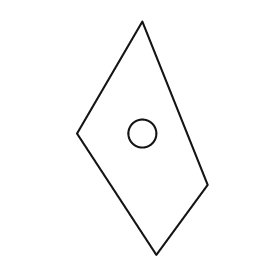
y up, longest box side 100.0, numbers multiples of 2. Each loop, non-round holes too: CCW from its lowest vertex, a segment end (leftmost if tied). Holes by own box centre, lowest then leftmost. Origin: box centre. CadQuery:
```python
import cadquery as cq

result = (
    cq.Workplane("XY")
    .moveTo(6.0, -50.0)
    .lineTo(28.0, -20.0)
    .lineTo(0.0, 50.0)
    .lineTo(-28.0, 2.0)
    .close()
    .moveTo(0.0, 2.0)
    .circle(6.0)
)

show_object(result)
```